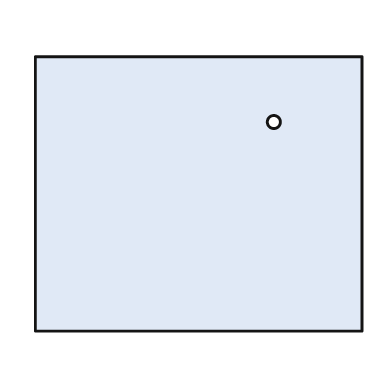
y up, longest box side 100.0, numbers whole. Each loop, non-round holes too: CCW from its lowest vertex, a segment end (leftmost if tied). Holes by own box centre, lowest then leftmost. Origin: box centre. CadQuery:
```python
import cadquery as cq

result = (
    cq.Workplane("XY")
    .moveTo(-50.0, -42.0)
    .lineTo(50.0, -42.0)
    .lineTo(50.0, 42.0)
    .lineTo(-50.0, 42.0)
    .close()
    .moveTo(23.0, 22.0)
    .circle(2.0)
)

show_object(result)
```